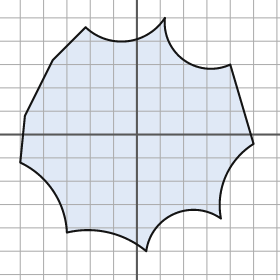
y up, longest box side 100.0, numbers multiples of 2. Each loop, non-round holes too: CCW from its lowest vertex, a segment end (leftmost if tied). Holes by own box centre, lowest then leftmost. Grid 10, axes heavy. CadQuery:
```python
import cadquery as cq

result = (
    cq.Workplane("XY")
    .moveTo(4.0, -50.0)
    .threePointArc((16.0, -34.0), (36.0, -36.0))
    .threePointArc((38.0, -18.0), (50.0, -4.0))
    .lineTo(40.0, 30.0)
    .threePointArc((20.0, 32.0), (12.0, 50.0))
    .threePointArc((-4.0, 40.0), (-22.0, 46.0))
    .lineTo(-36.0, 32.0)
    .lineTo(-48.0, 8.0)
    .lineTo(-50.0, -12.0)
    .threePointArc((-36.0, -24.0), (-30.0, -42.0))
    .threePointArc((-12.0, -42.0), (4.0, -50.0))
    .close()
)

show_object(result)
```